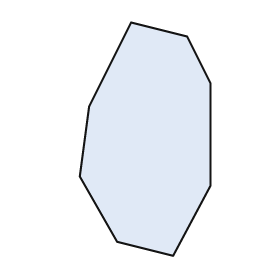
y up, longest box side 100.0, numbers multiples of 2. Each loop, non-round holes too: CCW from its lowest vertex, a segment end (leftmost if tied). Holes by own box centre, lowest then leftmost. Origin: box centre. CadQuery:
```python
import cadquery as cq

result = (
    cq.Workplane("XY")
    .moveTo(12.0, -50.0)
    .lineTo(28.0, -20.0)
    .lineTo(28.0, 24.0)
    .lineTo(18.0, 44.0)
    .lineTo(-6.0, 50.0)
    .lineTo(-24.0, 14.0)
    .lineTo(-28.0, -16.0)
    .lineTo(-12.0, -44.0)
    .close()
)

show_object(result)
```